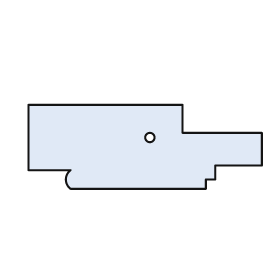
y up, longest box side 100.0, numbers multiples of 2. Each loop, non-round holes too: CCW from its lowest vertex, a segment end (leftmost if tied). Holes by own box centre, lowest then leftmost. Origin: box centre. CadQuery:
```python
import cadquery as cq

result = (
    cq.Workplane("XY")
    .moveTo(-32.0, -18.0)
    .lineTo(26.0, -18.0)
    .lineTo(26.0, -14.0)
    .lineTo(30.0, -14.0)
    .lineTo(30.0, -8.0)
    .lineTo(50.0, -8.0)
    .lineTo(50.0, 6.0)
    .lineTo(16.0, 6.0)
    .lineTo(16.0, 18.0)
    .lineTo(-50.0, 18.0)
    .lineTo(-50.0, -10.0)
    .lineTo(-32.0, -10.0)
    .threePointArc((-34.0, -14.0), (-32.0, -18.0))
    .close()
    .moveTo(2.0, 4.0)
    .circle(2.0)
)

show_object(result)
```